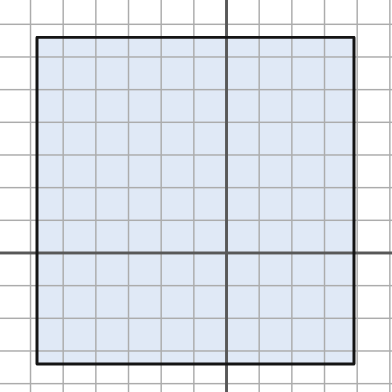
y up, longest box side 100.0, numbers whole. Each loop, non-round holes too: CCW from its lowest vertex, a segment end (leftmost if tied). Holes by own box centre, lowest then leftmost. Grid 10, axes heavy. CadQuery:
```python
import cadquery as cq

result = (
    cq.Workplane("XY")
    .moveTo(-58.0, -34.0)
    .lineTo(39.0, -34.0)
    .lineTo(39.0, 66.0)
    .lineTo(-58.0, 66.0)
    .close()
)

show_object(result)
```